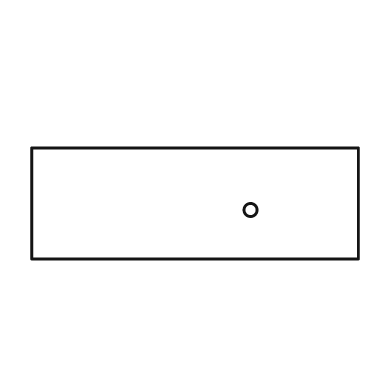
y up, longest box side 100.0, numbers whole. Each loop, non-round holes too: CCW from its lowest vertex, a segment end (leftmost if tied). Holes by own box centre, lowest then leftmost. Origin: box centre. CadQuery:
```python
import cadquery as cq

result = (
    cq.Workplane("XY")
    .moveTo(-50.0, -17.0)
    .lineTo(50.0, -17.0)
    .lineTo(50.0, 17.0)
    .lineTo(-50.0, 17.0)
    .close()
    .moveTo(17.0, -2.0)
    .circle(2.0)
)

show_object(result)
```